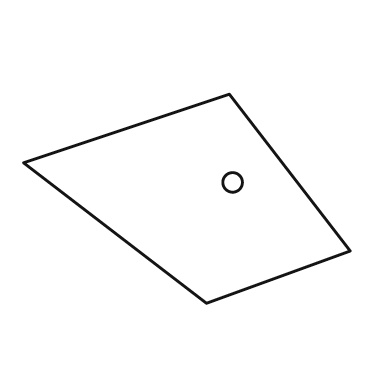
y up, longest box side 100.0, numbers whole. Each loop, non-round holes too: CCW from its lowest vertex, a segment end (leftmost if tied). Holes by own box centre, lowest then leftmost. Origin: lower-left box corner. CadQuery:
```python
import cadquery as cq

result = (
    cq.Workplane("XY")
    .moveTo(56.0, 0.0)
    .lineTo(100.0, 16.0)
    .lineTo(63.0, 64.0)
    .lineTo(0.0, 43.0)
    .close()
    .moveTo(64.0, 37.0)
    .circle(3.0)
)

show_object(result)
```